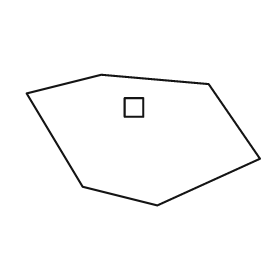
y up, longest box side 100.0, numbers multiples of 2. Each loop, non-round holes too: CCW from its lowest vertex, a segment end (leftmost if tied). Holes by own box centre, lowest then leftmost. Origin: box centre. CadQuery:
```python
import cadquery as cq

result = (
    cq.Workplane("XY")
    .moveTo(6.0, -28.0)
    .lineTo(50.0, -8.0)
    .lineTo(28.0, 24.0)
    .lineTo(-18.0, 28.0)
    .lineTo(-50.0, 20.0)
    .lineTo(-26.0, -20.0)
    .close()
    .moveTo(-8.0, 10.0)
    .lineTo(0.0, 10.0)
    .lineTo(0.0, 18.0)
    .lineTo(-8.0, 18.0)
    .close()
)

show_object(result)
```